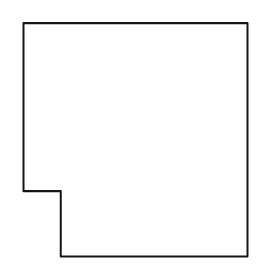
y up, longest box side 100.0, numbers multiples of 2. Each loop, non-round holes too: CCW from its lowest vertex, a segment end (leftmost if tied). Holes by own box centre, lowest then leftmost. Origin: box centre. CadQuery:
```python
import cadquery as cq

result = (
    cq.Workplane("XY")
    .moveTo(-32.0, -50.0)
    .lineTo(48.0, -50.0)
    .lineTo(48.0, 50.0)
    .lineTo(-48.0, 50.0)
    .lineTo(-48.0, -22.0)
    .lineTo(-32.0, -22.0)
    .close()
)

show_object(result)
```